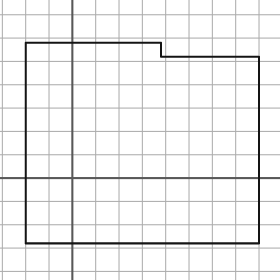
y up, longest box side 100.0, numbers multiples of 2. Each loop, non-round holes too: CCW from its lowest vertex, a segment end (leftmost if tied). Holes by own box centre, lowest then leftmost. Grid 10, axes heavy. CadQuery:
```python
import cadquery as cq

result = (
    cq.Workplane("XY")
    .moveTo(-20.0, -28.0)
    .lineTo(80.0, -28.0)
    .lineTo(80.0, 52.0)
    .lineTo(38.0, 52.0)
    .lineTo(38.0, 58.0)
    .lineTo(-20.0, 58.0)
    .close()
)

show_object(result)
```